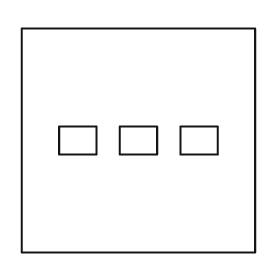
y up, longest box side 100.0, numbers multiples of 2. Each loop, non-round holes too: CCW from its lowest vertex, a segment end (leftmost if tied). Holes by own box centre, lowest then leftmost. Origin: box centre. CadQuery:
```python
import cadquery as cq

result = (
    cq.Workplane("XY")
    .moveTo(-50.0, -48.0)
    .lineTo(50.0, -48.0)
    .lineTo(50.0, 48.0)
    .lineTo(-50.0, 48.0)
    .close()
    .moveTo(-34.0, -6.0)
    .lineTo(-18.0, -6.0)
    .lineTo(-18.0, 6.0)
    .lineTo(-34.0, 6.0)
    .close()
    .moveTo(-8.0, -6.0)
    .lineTo(8.0, -6.0)
    .lineTo(8.0, 6.0)
    .lineTo(-8.0, 6.0)
    .close()
    .moveTo(18.0, -6.0)
    .lineTo(34.0, -6.0)
    .lineTo(34.0, 6.0)
    .lineTo(18.0, 6.0)
    .close()
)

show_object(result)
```